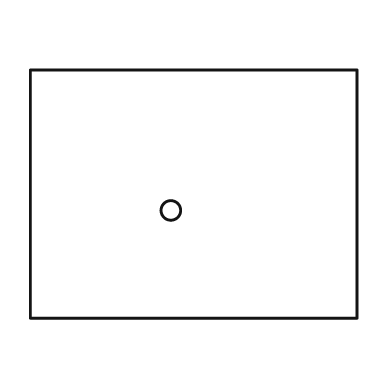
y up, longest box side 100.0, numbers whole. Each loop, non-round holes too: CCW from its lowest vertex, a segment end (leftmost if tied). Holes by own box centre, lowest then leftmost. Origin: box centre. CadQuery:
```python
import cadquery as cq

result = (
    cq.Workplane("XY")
    .moveTo(-50.0, -38.0)
    .lineTo(50.0, -38.0)
    .lineTo(50.0, 38.0)
    .lineTo(-50.0, 38.0)
    .close()
    .moveTo(-7.0, -5.0)
    .circle(3.0)
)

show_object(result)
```